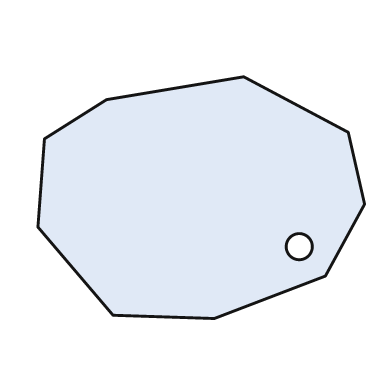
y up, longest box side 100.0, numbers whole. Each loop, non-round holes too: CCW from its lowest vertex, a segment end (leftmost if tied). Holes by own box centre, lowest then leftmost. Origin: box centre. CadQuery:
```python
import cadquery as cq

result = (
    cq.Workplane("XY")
    .moveTo(4.0, -37.0)
    .lineTo(38.0, -24.0)
    .lineTo(50.0, -2.0)
    .lineTo(45.0, 20.0)
    .lineTo(13.0, 37.0)
    .lineTo(-29.0, 30.0)
    .lineTo(-48.0, 18.0)
    .lineTo(-50.0, -9.0)
    .lineTo(-27.0, -36.0)
    .close()
    .moveTo(30.0, -15.0)
    .circle(4.0)
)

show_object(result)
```